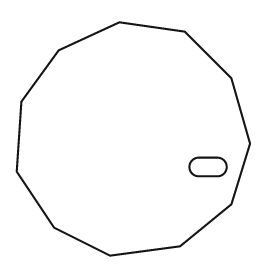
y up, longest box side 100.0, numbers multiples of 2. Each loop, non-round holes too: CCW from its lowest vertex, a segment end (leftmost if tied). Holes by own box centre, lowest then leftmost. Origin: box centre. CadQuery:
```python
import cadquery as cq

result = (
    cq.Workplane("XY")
    .moveTo(-10.0, -50.0)
    .lineTo(20.0, -46.0)
    .lineTo(42.0, -28.0)
    .lineTo(50.0, -2.0)
    .lineTo(42.0, 26.0)
    .lineTo(22.0, 46.0)
    .lineTo(-6.0, 50.0)
    .lineTo(-32.0, 38.0)
    .lineTo(-48.0, 16.0)
    .lineTo(-50.0, -14.0)
    .lineTo(-34.0, -38.0)
    .close()
    .moveTo(28.0, -16.0)
    .lineTo(36.0, -16.0)
    .threePointArc((40.0, -12.0), (36.0, -8.0))
    .lineTo(28.0, -8.0)
    .threePointArc((24.0, -12.0), (28.0, -16.0))
    .close()
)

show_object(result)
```